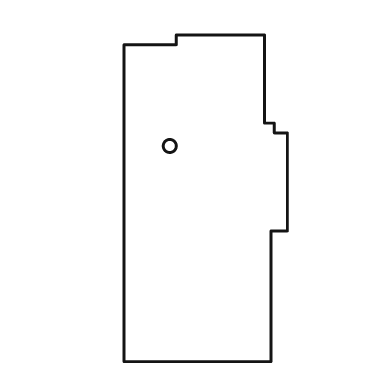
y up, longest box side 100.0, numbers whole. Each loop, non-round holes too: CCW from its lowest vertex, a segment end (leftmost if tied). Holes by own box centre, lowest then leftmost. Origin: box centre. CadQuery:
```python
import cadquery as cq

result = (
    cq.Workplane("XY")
    .moveTo(-25.0, -50.0)
    .lineTo(20.0, -50.0)
    .lineTo(20.0, -10.0)
    .lineTo(25.0, -10.0)
    .lineTo(25.0, 20.0)
    .lineTo(21.0, 20.0)
    .lineTo(21.0, 23.0)
    .lineTo(18.0, 23.0)
    .lineTo(18.0, 50.0)
    .lineTo(-9.0, 50.0)
    .lineTo(-9.0, 47.0)
    .lineTo(-25.0, 47.0)
    .close()
    .moveTo(-11.0, 16.0)
    .circle(2.0)
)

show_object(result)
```